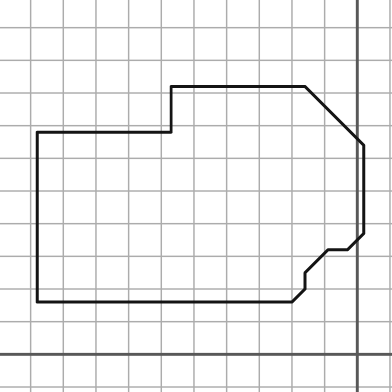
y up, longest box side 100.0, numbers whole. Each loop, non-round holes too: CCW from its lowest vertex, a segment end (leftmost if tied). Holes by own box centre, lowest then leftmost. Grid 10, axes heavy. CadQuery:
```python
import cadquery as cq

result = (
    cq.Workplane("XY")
    .moveTo(-98.0, 16.0)
    .lineTo(-20.0, 16.0)
    .lineTo(-16.0, 20.0)
    .lineTo(-16.0, 25.0)
    .lineTo(-9.0, 32.0)
    .lineTo(-3.0, 32.0)
    .lineTo(2.0, 37.0)
    .lineTo(2.0, 64.0)
    .lineTo(-16.0, 82.0)
    .lineTo(-57.0, 82.0)
    .lineTo(-57.0, 68.0)
    .lineTo(-98.0, 68.0)
    .close()
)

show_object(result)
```